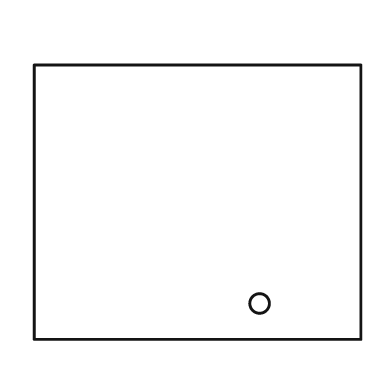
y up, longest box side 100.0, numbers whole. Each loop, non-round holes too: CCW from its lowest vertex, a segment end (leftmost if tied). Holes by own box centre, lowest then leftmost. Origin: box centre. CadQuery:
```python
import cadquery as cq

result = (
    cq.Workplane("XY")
    .moveTo(-50.0, -42.0)
    .lineTo(50.0, -42.0)
    .lineTo(50.0, 42.0)
    .lineTo(-50.0, 42.0)
    .close()
    .moveTo(19.0, -31.0)
    .circle(3.0)
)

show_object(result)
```